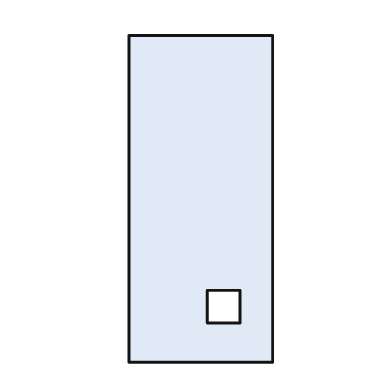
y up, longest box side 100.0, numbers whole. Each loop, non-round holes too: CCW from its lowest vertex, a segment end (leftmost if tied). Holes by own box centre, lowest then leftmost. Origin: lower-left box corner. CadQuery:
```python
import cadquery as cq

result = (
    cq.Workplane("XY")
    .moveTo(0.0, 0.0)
    .lineTo(44.0, 0.0)
    .lineTo(44.0, 100.0)
    .lineTo(0.0, 100.0)
    .close()
    .moveTo(24.0, 12.0)
    .lineTo(34.0, 12.0)
    .lineTo(34.0, 22.0)
    .lineTo(24.0, 22.0)
    .close()
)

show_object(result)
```